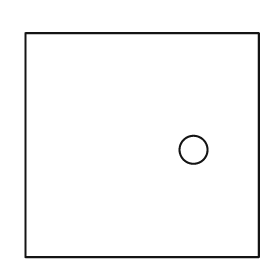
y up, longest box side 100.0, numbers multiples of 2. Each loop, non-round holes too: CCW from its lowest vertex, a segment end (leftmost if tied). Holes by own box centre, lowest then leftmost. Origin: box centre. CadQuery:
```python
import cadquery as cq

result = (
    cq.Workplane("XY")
    .moveTo(-50.0, -48.0)
    .lineTo(50.0, -48.0)
    .lineTo(50.0, 48.0)
    .lineTo(-50.0, 48.0)
    .close()
    .moveTo(22.0, -2.0)
    .circle(6.0)
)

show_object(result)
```